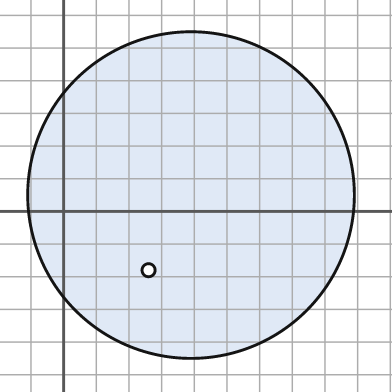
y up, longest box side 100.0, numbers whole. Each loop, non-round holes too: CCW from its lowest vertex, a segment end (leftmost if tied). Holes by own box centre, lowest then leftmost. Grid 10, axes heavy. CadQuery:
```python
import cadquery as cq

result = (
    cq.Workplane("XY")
    .moveTo(39.0, 5.0)
    .circle(50.0)
    .moveTo(26.0, -18.0)
    .circle(2.0)
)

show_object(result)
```